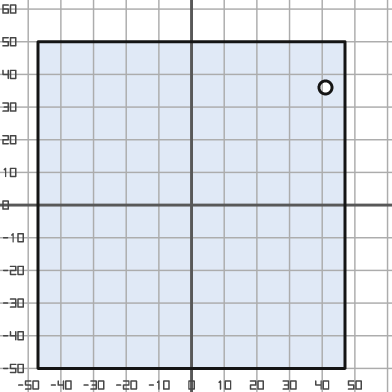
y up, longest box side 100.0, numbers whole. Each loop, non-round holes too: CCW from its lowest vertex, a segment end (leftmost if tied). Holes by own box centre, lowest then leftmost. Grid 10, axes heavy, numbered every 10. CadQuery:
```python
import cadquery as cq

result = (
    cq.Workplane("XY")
    .moveTo(-47.0, -50.0)
    .lineTo(47.0, -50.0)
    .lineTo(47.0, 50.0)
    .lineTo(-47.0, 50.0)
    .close()
    .moveTo(41.0, 36.0)
    .circle(2.0)
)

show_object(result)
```